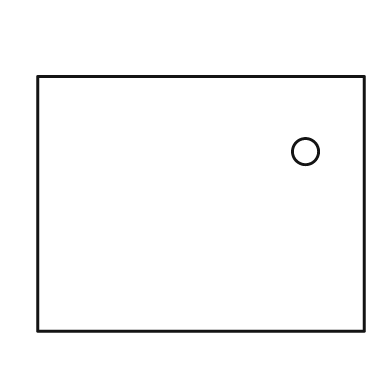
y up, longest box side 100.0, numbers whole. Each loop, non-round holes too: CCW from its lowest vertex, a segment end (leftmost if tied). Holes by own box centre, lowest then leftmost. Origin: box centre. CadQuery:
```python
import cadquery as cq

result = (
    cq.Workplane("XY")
    .moveTo(-50.0, -39.0)
    .lineTo(50.0, -39.0)
    .lineTo(50.0, 39.0)
    .lineTo(-50.0, 39.0)
    .close()
    .moveTo(32.0, 16.0)
    .circle(4.0)
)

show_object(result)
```